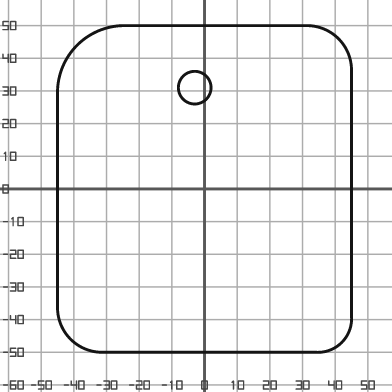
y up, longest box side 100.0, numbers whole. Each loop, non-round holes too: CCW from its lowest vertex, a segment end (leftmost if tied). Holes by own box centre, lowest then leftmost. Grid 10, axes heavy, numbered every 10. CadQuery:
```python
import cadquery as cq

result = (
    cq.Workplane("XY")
    .moveTo(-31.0, -50.0)
    .lineTo(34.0, -50.0)
    .threePointArc((42.0, -47.0), (45.0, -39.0))
    .lineTo(45.0, 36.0)
    .threePointArc((41.0, 46.0), (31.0, 50.0))
    .lineTo(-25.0, 50.0)
    .threePointArc((-39.0, 44.0), (-45.0, 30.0))
    .lineTo(-45.0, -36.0)
    .threePointArc((-41.0, -46.0), (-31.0, -50.0))
    .close()
    .moveTo(-3.0, 31.0)
    .circle(5.0)
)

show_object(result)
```